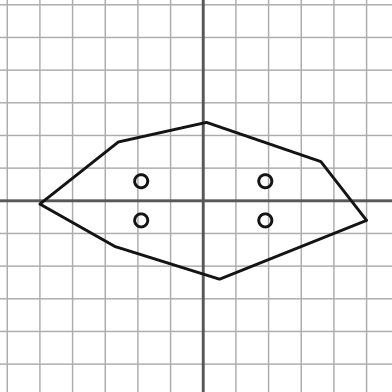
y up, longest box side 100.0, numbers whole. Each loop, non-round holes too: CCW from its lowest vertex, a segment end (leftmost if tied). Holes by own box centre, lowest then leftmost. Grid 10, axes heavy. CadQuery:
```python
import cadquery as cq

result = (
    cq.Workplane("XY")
    .moveTo(5.0, -24.0)
    .lineTo(50.0, -6.0)
    .lineTo(36.0, 12.0)
    .lineTo(1.0, 24.0)
    .lineTo(-26.0, 18.0)
    .lineTo(-50.0, -1.0)
    .lineTo(-27.0, -14.0)
    .close()
    .moveTo(-19.0, -6.0)
    .circle(2.0)
    .moveTo(19.0, -6.0)
    .circle(2.0)
    .moveTo(-19.0, 6.0)
    .circle(2.0)
    .moveTo(19.0, 6.0)
    .circle(2.0)
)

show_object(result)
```